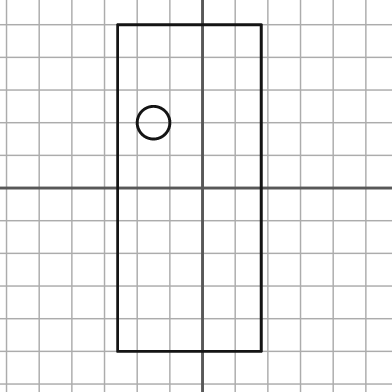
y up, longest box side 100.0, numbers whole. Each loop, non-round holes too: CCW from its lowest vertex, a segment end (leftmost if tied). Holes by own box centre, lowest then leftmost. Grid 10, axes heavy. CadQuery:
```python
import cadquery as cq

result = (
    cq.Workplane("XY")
    .moveTo(-26.0, -50.0)
    .lineTo(18.0, -50.0)
    .lineTo(18.0, 50.0)
    .lineTo(-26.0, 50.0)
    .close()
    .moveTo(-15.0, 20.0)
    .circle(5.0)
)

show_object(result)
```